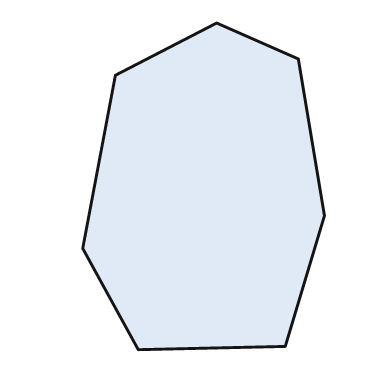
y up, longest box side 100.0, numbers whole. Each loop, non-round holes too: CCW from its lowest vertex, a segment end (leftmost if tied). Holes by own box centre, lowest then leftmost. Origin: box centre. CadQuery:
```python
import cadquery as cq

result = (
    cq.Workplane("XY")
    .moveTo(-20.0, -50.0)
    .lineTo(25.0, -49.0)
    .lineTo(37.0, -9.0)
    .lineTo(29.0, 39.0)
    .lineTo(4.0, 50.0)
    .lineTo(-27.0, 34.0)
    .lineTo(-37.0, -19.0)
    .close()
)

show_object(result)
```